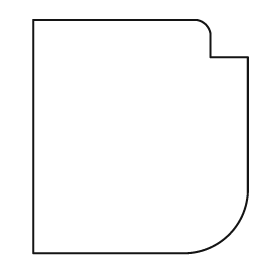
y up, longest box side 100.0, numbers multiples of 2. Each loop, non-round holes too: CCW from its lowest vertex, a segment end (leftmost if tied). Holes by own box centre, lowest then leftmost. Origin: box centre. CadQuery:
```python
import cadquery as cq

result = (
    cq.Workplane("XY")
    .moveTo(-46.0, -50.0)
    .lineTo(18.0, -50.0)
    .threePointArc((38.0, -42.0), (46.0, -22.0))
    .lineTo(46.0, 34.0)
    .lineTo(30.0, 34.0)
    .lineTo(30.0, 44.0)
    .threePointArc((28.0, 48.0), (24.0, 50.0))
    .lineTo(-46.0, 50.0)
    .close()
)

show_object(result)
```